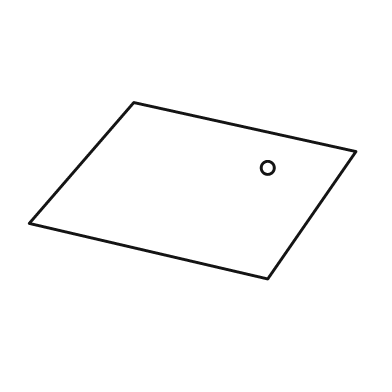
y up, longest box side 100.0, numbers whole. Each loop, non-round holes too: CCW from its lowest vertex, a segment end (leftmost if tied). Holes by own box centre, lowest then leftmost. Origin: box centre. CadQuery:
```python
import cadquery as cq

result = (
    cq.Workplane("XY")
    .moveTo(23.0, -27.0)
    .lineTo(50.0, 12.0)
    .lineTo(-18.0, 27.0)
    .lineTo(-50.0, -10.0)
    .close()
    .moveTo(23.0, 7.0)
    .circle(2.0)
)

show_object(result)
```